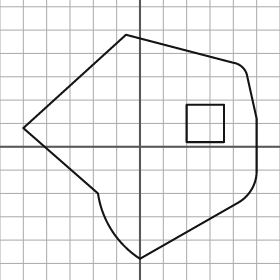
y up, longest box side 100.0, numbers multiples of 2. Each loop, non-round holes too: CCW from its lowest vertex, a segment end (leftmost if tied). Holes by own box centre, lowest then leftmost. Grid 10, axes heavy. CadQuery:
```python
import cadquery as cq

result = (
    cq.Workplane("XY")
    .moveTo(0.0, -48.0)
    .lineTo(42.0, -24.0)
    .threePointArc((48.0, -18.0), (50.0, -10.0))
    .lineTo(50.0, 12.0)
    .lineTo(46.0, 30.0)
    .threePointArc((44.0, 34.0), (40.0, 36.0))
    .lineTo(-6.0, 48.0)
    .lineTo(-50.0, 8.0)
    .lineTo(-18.0, -20.0)
    .threePointArc((-12.0, -36.0), (0.0, -48.0))
    .close()
    .moveTo(20.0, 2.0)
    .lineTo(36.0, 2.0)
    .lineTo(36.0, 18.0)
    .lineTo(20.0, 18.0)
    .close()
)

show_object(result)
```